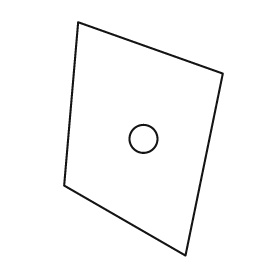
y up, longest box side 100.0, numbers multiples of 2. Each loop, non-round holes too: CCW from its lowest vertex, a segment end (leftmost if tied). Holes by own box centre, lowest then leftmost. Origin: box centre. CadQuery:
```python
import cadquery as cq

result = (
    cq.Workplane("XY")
    .moveTo(18.0, -50.0)
    .lineTo(34.0, 28.0)
    .lineTo(-28.0, 50.0)
    .lineTo(-34.0, -20.0)
    .close()
    .moveTo(0.0, 0.0)
    .circle(6.0)
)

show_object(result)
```